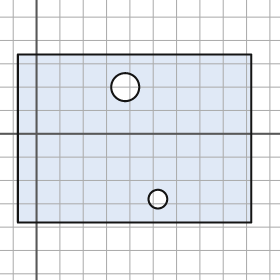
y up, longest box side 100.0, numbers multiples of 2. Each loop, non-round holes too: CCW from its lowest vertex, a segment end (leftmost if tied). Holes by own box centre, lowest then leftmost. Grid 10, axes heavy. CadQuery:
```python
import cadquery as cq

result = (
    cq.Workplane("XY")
    .moveTo(-8.0, -38.0)
    .lineTo(92.0, -38.0)
    .lineTo(92.0, 34.0)
    .lineTo(-8.0, 34.0)
    .close()
    .moveTo(52.0, -28.0)
    .circle(4.0)
    .moveTo(38.0, 20.0)
    .circle(6.0)
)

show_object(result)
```